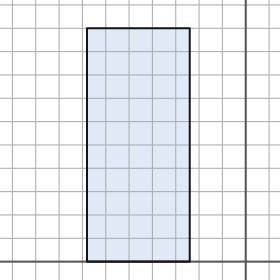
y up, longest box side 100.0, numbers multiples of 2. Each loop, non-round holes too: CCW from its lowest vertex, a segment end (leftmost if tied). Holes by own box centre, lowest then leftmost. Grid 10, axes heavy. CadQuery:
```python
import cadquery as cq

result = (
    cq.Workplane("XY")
    .moveTo(-68.0, 0.0)
    .lineTo(-24.0, 0.0)
    .lineTo(-24.0, 100.0)
    .lineTo(-68.0, 100.0)
    .close()
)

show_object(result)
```